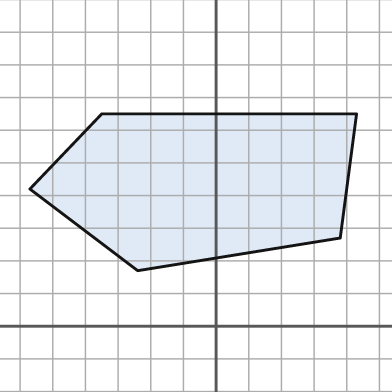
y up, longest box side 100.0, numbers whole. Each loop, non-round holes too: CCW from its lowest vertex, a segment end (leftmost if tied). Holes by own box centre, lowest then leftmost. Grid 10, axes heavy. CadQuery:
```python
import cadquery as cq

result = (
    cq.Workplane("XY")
    .moveTo(-24.0, 17.0)
    .lineTo(38.0, 27.0)
    .lineTo(43.0, 65.0)
    .lineTo(-35.0, 65.0)
    .lineTo(-57.0, 42.0)
    .close()
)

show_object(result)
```